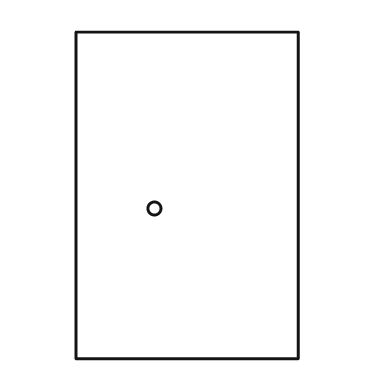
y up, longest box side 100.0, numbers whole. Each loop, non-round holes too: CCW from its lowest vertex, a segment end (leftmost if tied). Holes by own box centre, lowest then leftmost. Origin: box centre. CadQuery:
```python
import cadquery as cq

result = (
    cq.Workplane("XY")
    .moveTo(-34.0, -50.0)
    .lineTo(34.0, -50.0)
    .lineTo(34.0, 50.0)
    .lineTo(-34.0, 50.0)
    .close()
    .moveTo(-10.0, -4.0)
    .circle(2.0)
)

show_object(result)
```